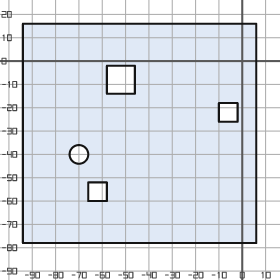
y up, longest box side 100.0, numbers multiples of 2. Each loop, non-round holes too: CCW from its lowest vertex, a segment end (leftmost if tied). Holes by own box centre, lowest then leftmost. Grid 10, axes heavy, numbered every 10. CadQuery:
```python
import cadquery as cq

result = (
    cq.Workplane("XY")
    .moveTo(-94.0, -78.0)
    .lineTo(6.0, -78.0)
    .lineTo(6.0, 16.0)
    .lineTo(-94.0, 16.0)
    .close()
    .moveTo(-66.0, -60.0)
    .lineTo(-58.0, -60.0)
    .lineTo(-58.0, -52.0)
    .lineTo(-66.0, -52.0)
    .close()
    .moveTo(-70.0, -40.0)
    .circle(4.0)
    .moveTo(-10.0, -26.0)
    .lineTo(-2.0, -26.0)
    .lineTo(-2.0, -18.0)
    .lineTo(-10.0, -18.0)
    .close()
    .moveTo(-58.0, -14.0)
    .lineTo(-46.0, -14.0)
    .lineTo(-46.0, -2.0)
    .lineTo(-58.0, -2.0)
    .close()
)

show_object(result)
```